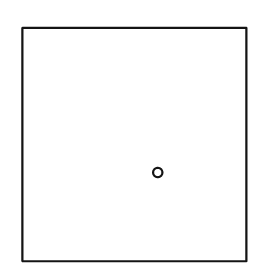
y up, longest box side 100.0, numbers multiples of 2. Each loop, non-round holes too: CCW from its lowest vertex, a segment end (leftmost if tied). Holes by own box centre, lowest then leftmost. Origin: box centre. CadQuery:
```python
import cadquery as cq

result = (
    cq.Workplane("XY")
    .moveTo(-48.0, -50.0)
    .lineTo(48.0, -50.0)
    .lineTo(48.0, 50.0)
    .lineTo(-48.0, 50.0)
    .close()
    .moveTo(10.0, -12.0)
    .circle(2.0)
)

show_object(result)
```